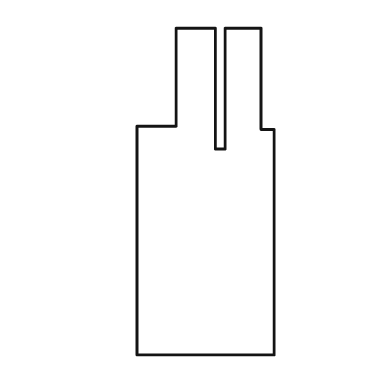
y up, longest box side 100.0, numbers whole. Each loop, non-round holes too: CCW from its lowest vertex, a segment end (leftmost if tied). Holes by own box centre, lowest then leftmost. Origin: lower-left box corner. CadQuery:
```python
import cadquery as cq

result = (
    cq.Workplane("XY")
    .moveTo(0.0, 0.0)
    .lineTo(42.0, 0.0)
    .lineTo(42.0, 69.0)
    .lineTo(38.0, 69.0)
    .lineTo(38.0, 100.0)
    .lineTo(27.0, 100.0)
    .lineTo(27.0, 63.0)
    .lineTo(24.0, 63.0)
    .lineTo(24.0, 100.0)
    .lineTo(12.0, 100.0)
    .lineTo(12.0, 70.0)
    .lineTo(0.0, 70.0)
    .close()
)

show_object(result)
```